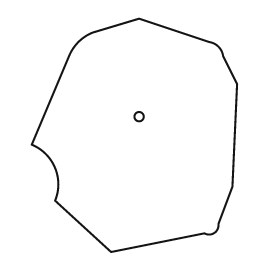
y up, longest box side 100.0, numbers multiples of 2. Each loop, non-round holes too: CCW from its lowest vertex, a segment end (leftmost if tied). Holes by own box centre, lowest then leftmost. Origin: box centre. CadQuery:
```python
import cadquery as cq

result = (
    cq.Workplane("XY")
    .moveTo(-10.0, -50.0)
    .lineTo(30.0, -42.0)
    .threePointArc((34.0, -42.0), (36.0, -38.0))
    .lineTo(42.0, -22.0)
    .lineTo(44.0, 22.0)
    .lineTo(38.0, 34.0)
    .threePointArc((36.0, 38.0), (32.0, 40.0))
    .lineTo(2.0, 50.0)
    .lineTo(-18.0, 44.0)
    .threePointArc((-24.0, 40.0), (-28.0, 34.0))
    .lineTo(-44.0, -4.0)
    .threePointArc((-34.0, -14.0), (-34.0, -28.0))
    .close()
    .moveTo(2.0, 8.0)
    .circle(2.0)
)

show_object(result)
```